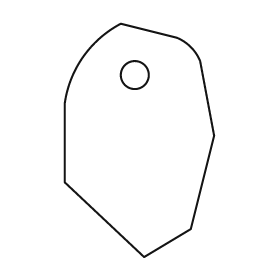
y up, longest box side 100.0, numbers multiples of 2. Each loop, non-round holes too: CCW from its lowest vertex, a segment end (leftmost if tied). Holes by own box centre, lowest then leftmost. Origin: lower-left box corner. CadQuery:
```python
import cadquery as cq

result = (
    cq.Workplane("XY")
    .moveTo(34.0, 0.0)
    .lineTo(54.0, 12.0)
    .lineTo(64.0, 52.0)
    .lineTo(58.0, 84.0)
    .threePointArc((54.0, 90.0), (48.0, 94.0))
    .lineTo(24.0, 100.0)
    .threePointArc((8.0, 86.0), (0.0, 66.0))
    .lineTo(0.0, 32.0)
    .close()
    .moveTo(30.0, 78.0)
    .circle(6.0)
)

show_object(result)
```